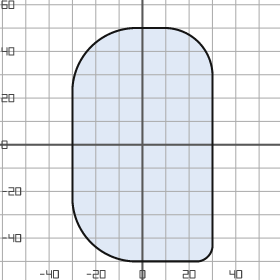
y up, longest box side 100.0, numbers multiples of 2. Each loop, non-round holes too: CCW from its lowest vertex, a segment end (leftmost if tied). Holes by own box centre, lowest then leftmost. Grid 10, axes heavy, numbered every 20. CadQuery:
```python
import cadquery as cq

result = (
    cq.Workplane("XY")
    .moveTo(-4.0, -50.0)
    .lineTo(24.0, -50.0)
    .threePointArc((28.0, -48.0), (30.0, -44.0))
    .lineTo(30.0, 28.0)
    .threePointArc((24.0, 44.0), (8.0, 50.0))
    .lineTo(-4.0, 50.0)
    .threePointArc((-22.0, 42.0), (-30.0, 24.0))
    .lineTo(-30.0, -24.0)
    .threePointArc((-22.0, -42.0), (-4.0, -50.0))
    .close()
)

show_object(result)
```